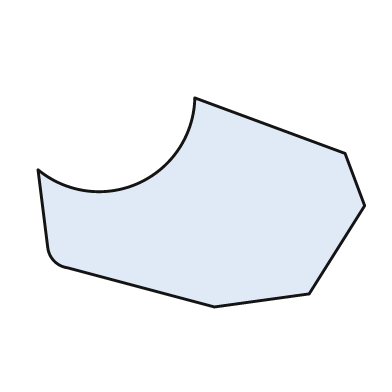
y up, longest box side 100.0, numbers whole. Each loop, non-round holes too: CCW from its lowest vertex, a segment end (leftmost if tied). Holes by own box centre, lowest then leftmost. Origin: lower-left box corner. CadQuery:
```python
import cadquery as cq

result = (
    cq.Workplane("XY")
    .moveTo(54.0, 0.0)
    .lineTo(83.0, 4.0)
    .lineTo(100.0, 31.0)
    .lineTo(94.0, 47.0)
    .lineTo(48.0, 64.0)
    .threePointArc((31.0, 38.0), (0.0, 42.0))
    .lineTo(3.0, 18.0)
    .threePointArc((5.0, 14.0), (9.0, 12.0))
    .close()
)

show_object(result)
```